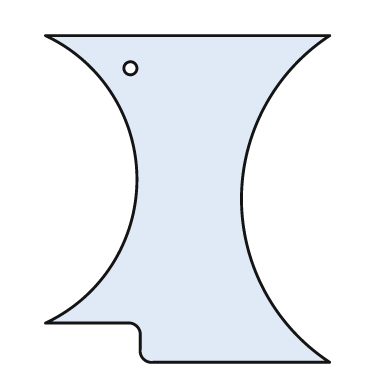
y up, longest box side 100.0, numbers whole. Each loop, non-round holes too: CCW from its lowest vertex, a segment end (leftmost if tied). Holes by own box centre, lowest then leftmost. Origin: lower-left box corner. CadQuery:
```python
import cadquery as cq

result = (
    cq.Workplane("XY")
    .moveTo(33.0, 0.0)
    .lineTo(87.0, 0.0)
    .threePointArc((60.0, 50.0), (87.0, 100.0))
    .lineTo(0.0, 100.0)
    .threePointArc((28.0, 56.0), (0.0, 12.0))
    .lineTo(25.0, 12.0)
    .threePointArc((28.0, 11.0), (29.0, 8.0))
    .lineTo(29.0, 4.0)
    .threePointArc((30.0, 1.0), (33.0, 0.0))
    .close()
    .moveTo(26.0, 90.0)
    .circle(2.0)
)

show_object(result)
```